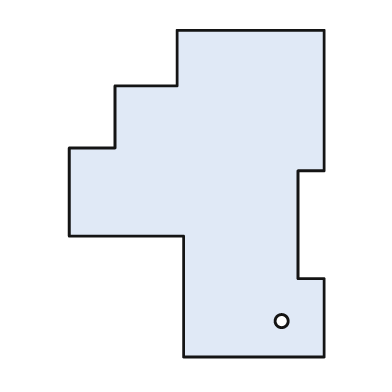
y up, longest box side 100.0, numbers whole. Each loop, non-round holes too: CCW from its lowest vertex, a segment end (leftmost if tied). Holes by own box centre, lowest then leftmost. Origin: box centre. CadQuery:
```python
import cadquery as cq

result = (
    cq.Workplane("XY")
    .moveTo(-4.0, -50.0)
    .lineTo(39.0, -50.0)
    .lineTo(39.0, -26.0)
    .lineTo(31.0, -26.0)
    .lineTo(31.0, 7.0)
    .lineTo(39.0, 7.0)
    .lineTo(39.0, 50.0)
    .lineTo(-6.0, 50.0)
    .lineTo(-6.0, 33.0)
    .lineTo(-25.0, 33.0)
    .lineTo(-25.0, 14.0)
    .lineTo(-39.0, 14.0)
    .lineTo(-39.0, -13.0)
    .lineTo(-4.0, -13.0)
    .close()
    .moveTo(26.0, -39.0)
    .circle(2.0)
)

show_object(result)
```